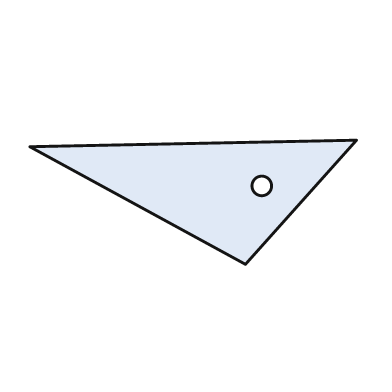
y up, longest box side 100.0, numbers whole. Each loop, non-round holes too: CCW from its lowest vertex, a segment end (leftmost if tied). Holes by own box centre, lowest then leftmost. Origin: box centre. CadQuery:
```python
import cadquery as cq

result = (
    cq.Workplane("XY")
    .moveTo(16.0, -19.0)
    .lineTo(50.0, 19.0)
    .lineTo(-50.0, 17.0)
    .close()
    .moveTo(21.0, 5.0)
    .circle(3.0)
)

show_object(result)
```